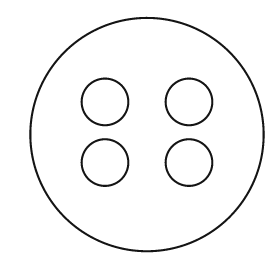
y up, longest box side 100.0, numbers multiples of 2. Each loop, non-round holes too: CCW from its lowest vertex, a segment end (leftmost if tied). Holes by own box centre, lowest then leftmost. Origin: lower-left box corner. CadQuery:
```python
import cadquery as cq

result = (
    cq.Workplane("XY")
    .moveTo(50.0, 50.0)
    .circle(50.0)
    .moveTo(32.0, 38.0)
    .circle(10.0)
    .moveTo(68.0, 38.0)
    .circle(10.0)
    .moveTo(32.0, 64.0)
    .circle(10.0)
    .moveTo(68.0, 64.0)
    .circle(10.0)
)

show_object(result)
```